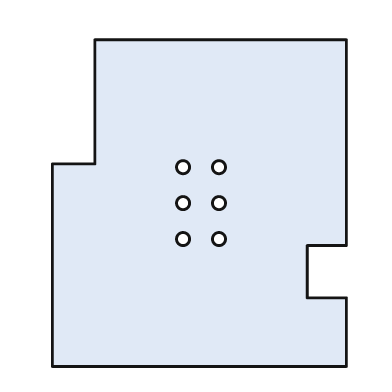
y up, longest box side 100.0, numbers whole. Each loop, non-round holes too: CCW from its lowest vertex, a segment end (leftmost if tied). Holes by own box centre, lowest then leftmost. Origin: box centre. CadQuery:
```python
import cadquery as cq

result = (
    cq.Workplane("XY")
    .moveTo(-45.0, -50.0)
    .lineTo(45.0, -50.0)
    .lineTo(45.0, -29.0)
    .lineTo(33.0, -29.0)
    .lineTo(33.0, -13.0)
    .lineTo(45.0, -13.0)
    .lineTo(45.0, 50.0)
    .lineTo(-32.0, 50.0)
    .lineTo(-32.0, 12.0)
    .lineTo(-45.0, 12.0)
    .close()
    .moveTo(-5.0, -11.0)
    .circle(2.0)
    .moveTo(6.0, -11.0)
    .circle(2.0)
    .moveTo(-5.0, 0.0)
    .circle(2.0)
    .moveTo(6.0, 0.0)
    .circle(2.0)
    .moveTo(-5.0, 11.0)
    .circle(2.0)
    .moveTo(6.0, 11.0)
    .circle(2.0)
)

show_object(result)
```